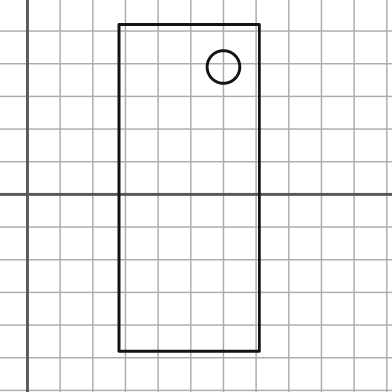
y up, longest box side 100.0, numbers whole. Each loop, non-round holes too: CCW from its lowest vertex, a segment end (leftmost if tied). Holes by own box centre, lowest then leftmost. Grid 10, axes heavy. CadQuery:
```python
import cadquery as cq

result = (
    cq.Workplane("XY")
    .moveTo(28.0, -48.0)
    .lineTo(71.0, -48.0)
    .lineTo(71.0, 52.0)
    .lineTo(28.0, 52.0)
    .close()
    .moveTo(60.0, 39.0)
    .circle(5.0)
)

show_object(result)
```